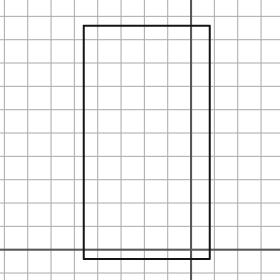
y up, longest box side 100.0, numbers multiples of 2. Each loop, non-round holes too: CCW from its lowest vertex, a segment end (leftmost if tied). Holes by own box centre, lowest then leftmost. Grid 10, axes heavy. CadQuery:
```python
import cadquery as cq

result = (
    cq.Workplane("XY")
    .moveTo(-46.0, -4.0)
    .lineTo(8.0, -4.0)
    .lineTo(8.0, 96.0)
    .lineTo(-46.0, 96.0)
    .close()
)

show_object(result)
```